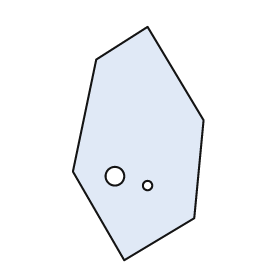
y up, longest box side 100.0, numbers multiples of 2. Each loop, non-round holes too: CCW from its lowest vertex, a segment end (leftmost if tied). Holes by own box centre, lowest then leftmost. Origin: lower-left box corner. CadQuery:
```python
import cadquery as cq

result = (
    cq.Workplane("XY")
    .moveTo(22.0, 0.0)
    .lineTo(52.0, 18.0)
    .lineTo(56.0, 60.0)
    .lineTo(32.0, 100.0)
    .lineTo(10.0, 86.0)
    .lineTo(0.0, 38.0)
    .close()
    .moveTo(32.0, 32.0)
    .circle(2.0)
    .moveTo(18.0, 36.0)
    .circle(4.0)
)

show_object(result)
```